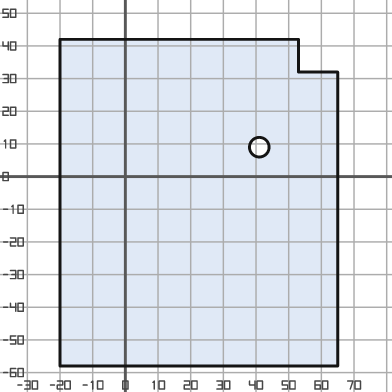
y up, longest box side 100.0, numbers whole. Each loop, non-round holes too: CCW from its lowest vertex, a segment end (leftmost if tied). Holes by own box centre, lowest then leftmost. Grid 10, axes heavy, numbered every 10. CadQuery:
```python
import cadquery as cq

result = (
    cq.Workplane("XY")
    .moveTo(-20.0, -58.0)
    .lineTo(65.0, -58.0)
    .lineTo(65.0, 32.0)
    .lineTo(53.0, 32.0)
    .lineTo(53.0, 42.0)
    .lineTo(-20.0, 42.0)
    .close()
    .moveTo(41.0, 9.0)
    .circle(3.0)
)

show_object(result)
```